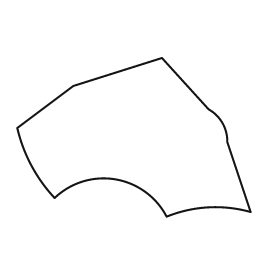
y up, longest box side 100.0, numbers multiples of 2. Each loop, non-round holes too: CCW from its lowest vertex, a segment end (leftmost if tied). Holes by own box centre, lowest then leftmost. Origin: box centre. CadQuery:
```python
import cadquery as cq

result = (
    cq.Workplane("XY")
    .moveTo(14.0, -34.0)
    .threePointArc((32.0, -30.0), (50.0, -32.0))
    .lineTo(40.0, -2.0)
    .threePointArc((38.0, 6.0), (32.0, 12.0))
    .lineTo(12.0, 34.0)
    .lineTo(-26.0, 22.0)
    .lineTo(-50.0, 4.0)
    .threePointArc((-44.0, -12.0), (-34.0, -26.0))
    .threePointArc((-8.0, -18.0), (14.0, -34.0))
    .close()
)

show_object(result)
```